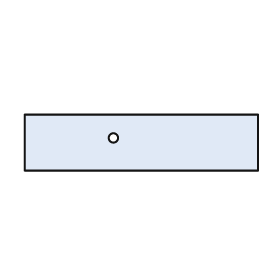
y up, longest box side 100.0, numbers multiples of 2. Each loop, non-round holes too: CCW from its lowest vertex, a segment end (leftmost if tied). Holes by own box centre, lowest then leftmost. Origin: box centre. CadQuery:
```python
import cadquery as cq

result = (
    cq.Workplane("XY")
    .moveTo(-50.0, -12.0)
    .lineTo(50.0, -12.0)
    .lineTo(50.0, 12.0)
    .lineTo(-50.0, 12.0)
    .close()
    .moveTo(-12.0, 2.0)
    .circle(2.0)
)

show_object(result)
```